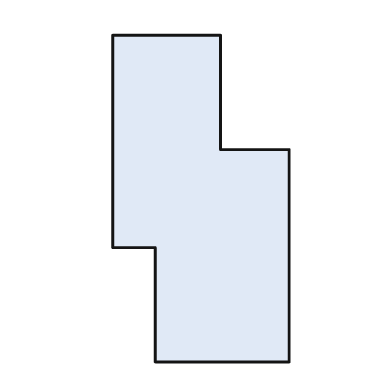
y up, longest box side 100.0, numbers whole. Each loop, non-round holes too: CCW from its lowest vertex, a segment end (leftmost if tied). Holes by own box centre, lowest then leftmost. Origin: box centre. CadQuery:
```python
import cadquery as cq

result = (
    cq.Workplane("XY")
    .moveTo(-14.0, -50.0)
    .lineTo(27.0, -50.0)
    .lineTo(27.0, 15.0)
    .lineTo(6.0, 15.0)
    .lineTo(6.0, 50.0)
    .lineTo(-27.0, 50.0)
    .lineTo(-27.0, -15.0)
    .lineTo(-14.0, -15.0)
    .close()
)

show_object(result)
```